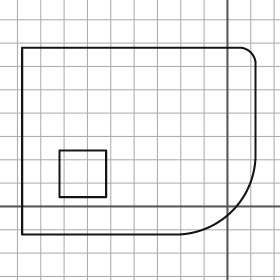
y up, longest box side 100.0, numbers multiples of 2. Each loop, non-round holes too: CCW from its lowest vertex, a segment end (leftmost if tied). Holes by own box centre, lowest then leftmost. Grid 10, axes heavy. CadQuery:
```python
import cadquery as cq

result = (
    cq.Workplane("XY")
    .moveTo(-88.0, -12.0)
    .lineTo(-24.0, -12.0)
    .threePointArc((2.0, -2.0), (12.0, 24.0))
    .lineTo(12.0, 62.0)
    .threePointArc((10.0, 66.0), (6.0, 68.0))
    .lineTo(-88.0, 68.0)
    .close()
    .moveTo(-72.0, 4.0)
    .lineTo(-52.0, 4.0)
    .lineTo(-52.0, 24.0)
    .lineTo(-72.0, 24.0)
    .close()
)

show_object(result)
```